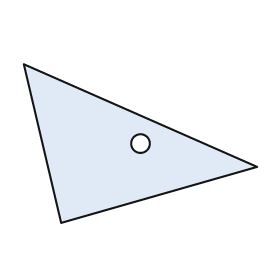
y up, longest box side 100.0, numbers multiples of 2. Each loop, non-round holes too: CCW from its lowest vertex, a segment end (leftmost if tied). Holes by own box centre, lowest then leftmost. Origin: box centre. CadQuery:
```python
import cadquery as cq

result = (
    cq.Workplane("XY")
    .moveTo(-34.0, -34.0)
    .lineTo(50.0, -10.0)
    .lineTo(-50.0, 34.0)
    .close()
    .moveTo(0.0, 0.0)
    .circle(4.0)
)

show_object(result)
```